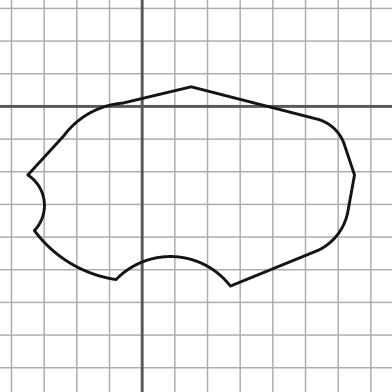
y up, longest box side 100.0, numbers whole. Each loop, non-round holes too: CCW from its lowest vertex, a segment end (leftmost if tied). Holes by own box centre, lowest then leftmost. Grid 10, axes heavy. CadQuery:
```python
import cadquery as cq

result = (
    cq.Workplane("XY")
    .moveTo(27.0, -55.0)
    .lineTo(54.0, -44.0)
    .threePointArc((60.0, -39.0), (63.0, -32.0))
    .lineTo(65.0, -21.0)
    .lineTo(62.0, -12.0)
    .threePointArc((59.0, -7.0), (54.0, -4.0))
    .lineTo(15.0, 6.0)
    .lineTo(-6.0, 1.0)
    .threePointArc((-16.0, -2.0), (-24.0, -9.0))
    .lineTo(-35.0, -21.0)
    .threePointArc((-30.0, -29.0), (-33.0, -38.0))
    .threePointArc((-22.0, -48.0), (-8.0, -53.0))
    .threePointArc((10.0, -46.0), (27.0, -55.0))
    .close()
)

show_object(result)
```